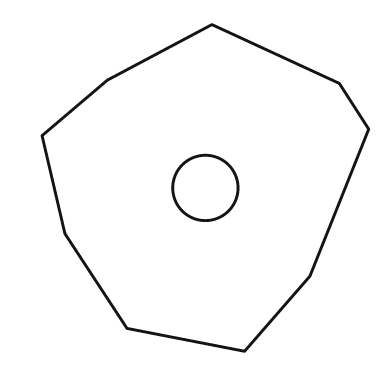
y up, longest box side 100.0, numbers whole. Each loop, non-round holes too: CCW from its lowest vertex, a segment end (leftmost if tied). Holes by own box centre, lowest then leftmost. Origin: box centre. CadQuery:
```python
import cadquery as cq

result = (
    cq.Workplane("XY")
    .moveTo(12.0, -50.0)
    .lineTo(32.0, -27.0)
    .lineTo(50.0, 18.0)
    .lineTo(41.0, 32.0)
    .lineTo(2.0, 50.0)
    .lineTo(-30.0, 33.0)
    .lineTo(-50.0, 16.0)
    .lineTo(-43.0, -14.0)
    .lineTo(-24.0, -43.0)
    .close()
    .moveTo(0.0, 0.0)
    .circle(10.0)
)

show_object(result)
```